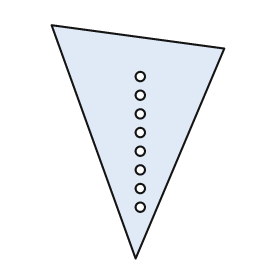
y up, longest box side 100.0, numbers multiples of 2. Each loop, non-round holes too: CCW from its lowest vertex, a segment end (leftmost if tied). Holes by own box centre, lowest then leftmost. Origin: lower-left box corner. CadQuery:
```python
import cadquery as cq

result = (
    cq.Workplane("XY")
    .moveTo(36.0, 0.0)
    .lineTo(74.0, 90.0)
    .lineTo(0.0, 100.0)
    .close()
    .moveTo(38.0, 22.0)
    .circle(2.0)
    .moveTo(38.0, 30.0)
    .circle(2.0)
    .moveTo(38.0, 38.0)
    .circle(2.0)
    .moveTo(38.0, 46.0)
    .circle(2.0)
    .moveTo(38.0, 54.0)
    .circle(2.0)
    .moveTo(38.0, 62.0)
    .circle(2.0)
    .moveTo(38.0, 70.0)
    .circle(2.0)
    .moveTo(38.0, 78.0)
    .circle(2.0)
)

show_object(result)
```